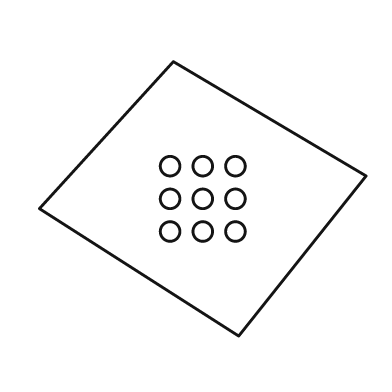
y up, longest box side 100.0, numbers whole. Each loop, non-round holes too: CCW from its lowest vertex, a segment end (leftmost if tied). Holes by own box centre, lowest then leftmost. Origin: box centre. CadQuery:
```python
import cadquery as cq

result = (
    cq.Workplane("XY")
    .moveTo(11.0, -42.0)
    .lineTo(50.0, 7.0)
    .lineTo(-9.0, 42.0)
    .lineTo(-50.0, -3.0)
    .close()
    .moveTo(-10.0, -10.0)
    .circle(3.0)
    .moveTo(0.0, -10.0)
    .circle(3.0)
    .moveTo(10.0, -10.0)
    .circle(3.0)
    .moveTo(-10.0, 0.0)
    .circle(3.0)
    .moveTo(0.0, 0.0)
    .circle(3.0)
    .moveTo(10.0, 0.0)
    .circle(3.0)
    .moveTo(-10.0, 10.0)
    .circle(3.0)
    .moveTo(0.0, 10.0)
    .circle(3.0)
    .moveTo(10.0, 10.0)
    .circle(3.0)
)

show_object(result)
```